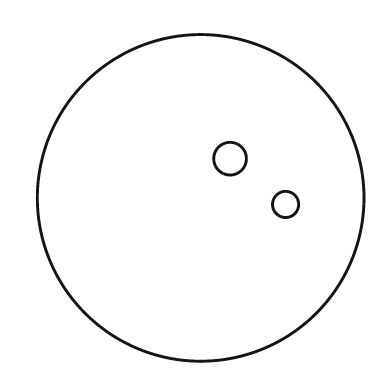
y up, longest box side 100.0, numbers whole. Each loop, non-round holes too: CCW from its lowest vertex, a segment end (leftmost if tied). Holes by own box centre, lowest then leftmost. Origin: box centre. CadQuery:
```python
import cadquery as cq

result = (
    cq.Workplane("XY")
    .moveTo(0.0, 0.0)
    .circle(50.0)
    .moveTo(26.0, -2.0)
    .circle(4.0)
    .moveTo(9.0, 12.0)
    .circle(5.0)
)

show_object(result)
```